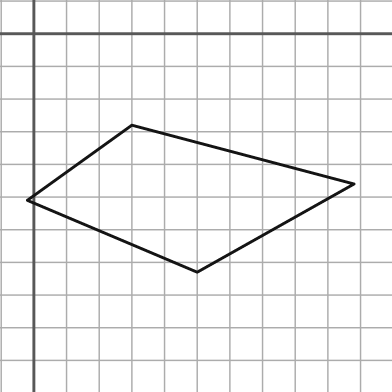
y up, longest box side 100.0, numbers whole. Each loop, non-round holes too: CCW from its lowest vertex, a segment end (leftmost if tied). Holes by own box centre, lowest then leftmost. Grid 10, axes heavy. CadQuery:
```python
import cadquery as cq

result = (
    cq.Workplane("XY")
    .moveTo(50.0, -73.0)
    .lineTo(98.0, -46.0)
    .lineTo(30.0, -28.0)
    .lineTo(-2.0, -51.0)
    .close()
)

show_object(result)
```